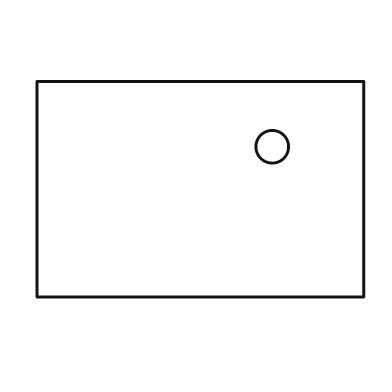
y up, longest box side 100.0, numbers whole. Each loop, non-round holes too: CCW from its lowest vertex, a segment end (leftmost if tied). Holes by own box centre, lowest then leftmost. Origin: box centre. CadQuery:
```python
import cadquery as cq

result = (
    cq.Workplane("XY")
    .moveTo(-50.0, -33.0)
    .lineTo(50.0, -33.0)
    .lineTo(50.0, 33.0)
    .lineTo(-50.0, 33.0)
    .close()
    .moveTo(22.0, 13.0)
    .circle(5.0)
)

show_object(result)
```